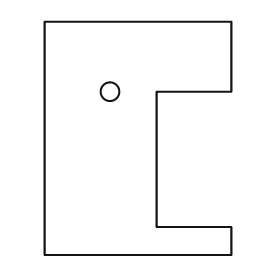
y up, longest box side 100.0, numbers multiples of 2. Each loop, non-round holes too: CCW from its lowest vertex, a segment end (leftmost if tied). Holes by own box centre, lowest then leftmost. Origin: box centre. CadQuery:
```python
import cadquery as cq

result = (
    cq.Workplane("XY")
    .moveTo(-40.0, -50.0)
    .lineTo(40.0, -50.0)
    .lineTo(40.0, -38.0)
    .lineTo(8.0, -38.0)
    .lineTo(8.0, 20.0)
    .lineTo(40.0, 20.0)
    .lineTo(40.0, 50.0)
    .lineTo(-40.0, 50.0)
    .close()
    .moveTo(-12.0, 20.0)
    .circle(4.0)
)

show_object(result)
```